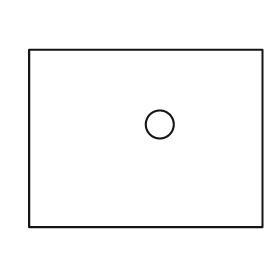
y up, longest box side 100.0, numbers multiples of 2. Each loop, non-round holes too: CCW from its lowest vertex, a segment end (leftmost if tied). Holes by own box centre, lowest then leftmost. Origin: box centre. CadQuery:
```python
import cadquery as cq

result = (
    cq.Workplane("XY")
    .moveTo(-50.0, -38.0)
    .lineTo(50.0, -38.0)
    .lineTo(50.0, 38.0)
    .lineTo(-50.0, 38.0)
    .close()
    .moveTo(6.0, 6.0)
    .circle(6.0)
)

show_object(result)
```